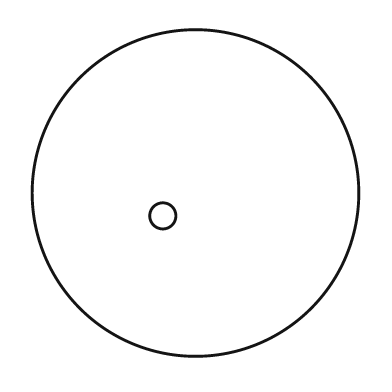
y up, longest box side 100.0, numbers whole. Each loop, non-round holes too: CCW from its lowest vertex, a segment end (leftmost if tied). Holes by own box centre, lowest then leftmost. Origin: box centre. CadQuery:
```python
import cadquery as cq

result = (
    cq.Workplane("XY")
    .moveTo(0.0, 0.0)
    .circle(50.0)
    .moveTo(-10.0, -7.0)
    .circle(4.0)
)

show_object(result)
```